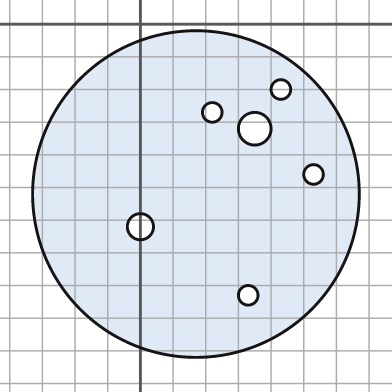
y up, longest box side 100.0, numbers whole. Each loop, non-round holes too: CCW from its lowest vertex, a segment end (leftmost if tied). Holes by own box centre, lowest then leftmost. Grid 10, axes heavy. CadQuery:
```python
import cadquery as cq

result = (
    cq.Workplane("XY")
    .moveTo(17.0, -52.0)
    .circle(50.0)
    .moveTo(33.0, -83.0)
    .circle(3.0)
    .moveTo(0.0, -62.0)
    .circle(4.0)
    .moveTo(53.0, -46.0)
    .circle(3.0)
    .moveTo(35.0, -32.0)
    .circle(5.0)
    .moveTo(22.0, -27.0)
    .circle(3.0)
    .moveTo(43.0, -20.0)
    .circle(3.0)
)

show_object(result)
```